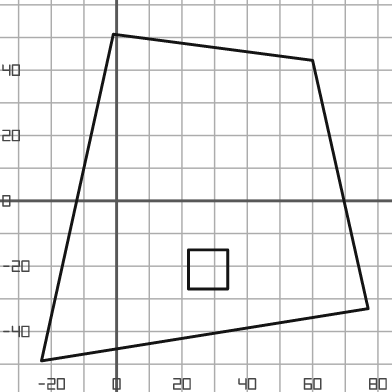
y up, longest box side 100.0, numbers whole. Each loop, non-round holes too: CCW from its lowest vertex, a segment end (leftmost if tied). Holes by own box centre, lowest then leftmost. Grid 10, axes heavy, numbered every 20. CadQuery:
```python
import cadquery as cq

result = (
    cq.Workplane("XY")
    .moveTo(-23.0, -49.0)
    .lineTo(77.0, -33.0)
    .lineTo(60.0, 43.0)
    .lineTo(-1.0, 51.0)
    .close()
    .moveTo(22.0, -27.0)
    .lineTo(34.0, -27.0)
    .lineTo(34.0, -15.0)
    .lineTo(22.0, -15.0)
    .close()
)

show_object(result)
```